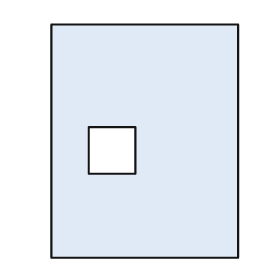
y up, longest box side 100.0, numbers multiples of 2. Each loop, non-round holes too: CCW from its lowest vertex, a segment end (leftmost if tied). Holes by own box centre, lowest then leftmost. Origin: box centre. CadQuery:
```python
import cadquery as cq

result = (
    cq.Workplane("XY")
    .moveTo(-40.0, -50.0)
    .lineTo(40.0, -50.0)
    .lineTo(40.0, 50.0)
    .lineTo(-40.0, 50.0)
    .close()
    .moveTo(-24.0, -14.0)
    .lineTo(-4.0, -14.0)
    .lineTo(-4.0, 6.0)
    .lineTo(-24.0, 6.0)
    .close()
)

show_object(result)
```